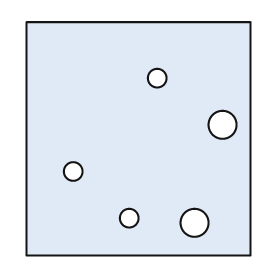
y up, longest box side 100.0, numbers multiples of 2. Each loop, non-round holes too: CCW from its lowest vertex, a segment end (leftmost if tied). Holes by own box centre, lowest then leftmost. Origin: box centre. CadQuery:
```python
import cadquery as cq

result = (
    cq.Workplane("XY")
    .moveTo(-48.0, -50.0)
    .lineTo(48.0, -50.0)
    .lineTo(48.0, 50.0)
    .lineTo(-48.0, 50.0)
    .close()
    .moveTo(24.0, -36.0)
    .circle(6.0)
    .moveTo(-4.0, -34.0)
    .circle(4.0)
    .moveTo(-28.0, -14.0)
    .circle(4.0)
    .moveTo(36.0, 6.0)
    .circle(6.0)
    .moveTo(8.0, 26.0)
    .circle(4.0)
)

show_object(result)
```